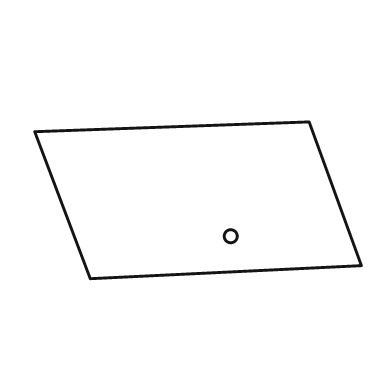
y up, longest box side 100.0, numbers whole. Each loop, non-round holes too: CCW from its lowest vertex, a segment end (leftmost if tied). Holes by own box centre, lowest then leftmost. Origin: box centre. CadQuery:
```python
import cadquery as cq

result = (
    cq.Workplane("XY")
    .moveTo(-33.0, -24.0)
    .lineTo(50.0, -20.0)
    .lineTo(34.0, 24.0)
    .lineTo(-50.0, 21.0)
    .close()
    .moveTo(10.0, -11.0)
    .circle(2.0)
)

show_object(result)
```